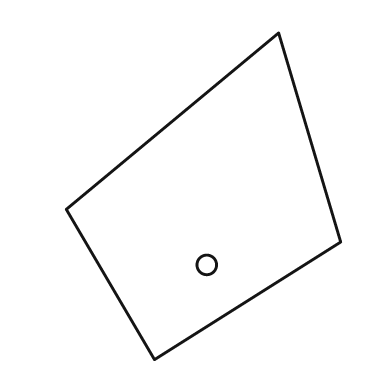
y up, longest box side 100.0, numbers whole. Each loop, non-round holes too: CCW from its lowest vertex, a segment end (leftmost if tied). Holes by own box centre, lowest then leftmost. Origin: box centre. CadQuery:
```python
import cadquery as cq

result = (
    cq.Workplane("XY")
    .moveTo(-15.0, -50.0)
    .lineTo(42.0, -14.0)
    .lineTo(23.0, 50.0)
    .lineTo(-42.0, -4.0)
    .close()
    .moveTo(1.0, -21.0)
    .circle(3.0)
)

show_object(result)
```